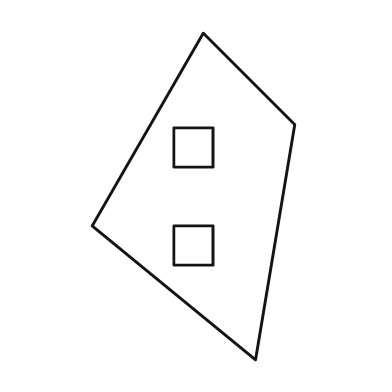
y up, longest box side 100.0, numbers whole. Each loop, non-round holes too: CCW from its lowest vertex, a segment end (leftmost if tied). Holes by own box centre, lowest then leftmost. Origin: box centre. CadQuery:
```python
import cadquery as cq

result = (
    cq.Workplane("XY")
    .moveTo(19.0, -50.0)
    .lineTo(31.0, 22.0)
    .lineTo(3.0, 50.0)
    .lineTo(-31.0, -9.0)
    .close()
    .moveTo(-6.0, -21.0)
    .lineTo(6.0, -21.0)
    .lineTo(6.0, -9.0)
    .lineTo(-6.0, -9.0)
    .close()
    .moveTo(-6.0, 9.0)
    .lineTo(6.0, 9.0)
    .lineTo(6.0, 21.0)
    .lineTo(-6.0, 21.0)
    .close()
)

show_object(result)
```